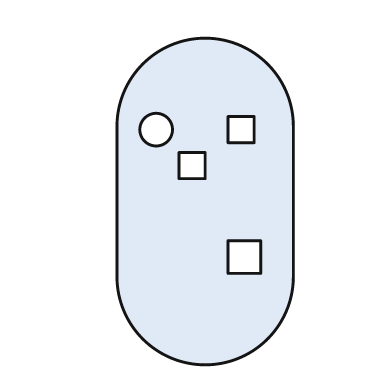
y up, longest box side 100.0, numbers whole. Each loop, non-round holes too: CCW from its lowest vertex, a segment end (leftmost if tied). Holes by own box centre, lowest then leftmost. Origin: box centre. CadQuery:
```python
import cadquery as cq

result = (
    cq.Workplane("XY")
    .moveTo(-27.0, -23.0)
    .threePointArc((0.0, -50.0), (27.0, -23.0))
    .lineTo(27.0, 23.0)
    .threePointArc((0.0, 50.0), (-27.0, 23.0))
    .close()
    .moveTo(7.0, -22.0)
    .lineTo(17.0, -22.0)
    .lineTo(17.0, -12.0)
    .lineTo(7.0, -12.0)
    .close()
    .moveTo(-8.0, 7.0)
    .lineTo(0.0, 7.0)
    .lineTo(0.0, 15.0)
    .lineTo(-8.0, 15.0)
    .close()
    .moveTo(-15.0, 22.0)
    .circle(5.0)
    .moveTo(7.0, 18.0)
    .lineTo(15.0, 18.0)
    .lineTo(15.0, 26.0)
    .lineTo(7.0, 26.0)
    .close()
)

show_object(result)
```